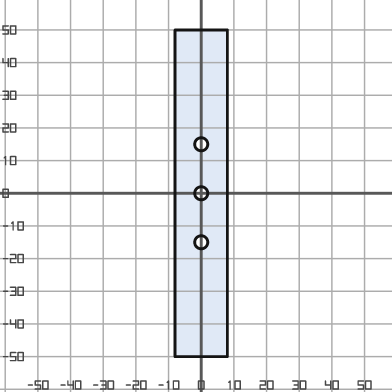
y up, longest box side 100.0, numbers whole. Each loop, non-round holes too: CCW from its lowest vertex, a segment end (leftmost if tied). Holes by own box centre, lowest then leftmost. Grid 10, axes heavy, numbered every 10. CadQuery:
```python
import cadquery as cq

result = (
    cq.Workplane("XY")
    .moveTo(-8.0, -50.0)
    .lineTo(8.0, -50.0)
    .lineTo(8.0, 50.0)
    .lineTo(-8.0, 50.0)
    .close()
    .moveTo(0.0, -15.0)
    .circle(2.0)
    .moveTo(0.0, 0.0)
    .circle(2.0)
    .moveTo(0.0, 15.0)
    .circle(2.0)
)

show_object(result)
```